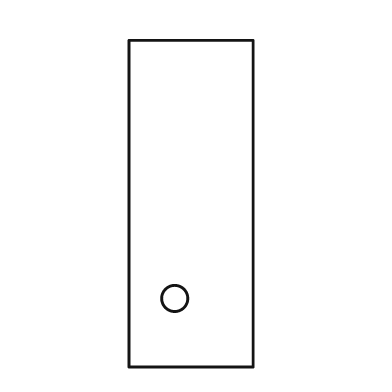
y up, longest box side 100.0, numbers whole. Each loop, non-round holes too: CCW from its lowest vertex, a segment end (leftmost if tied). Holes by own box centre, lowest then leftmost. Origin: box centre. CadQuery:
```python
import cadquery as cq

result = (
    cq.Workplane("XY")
    .moveTo(-19.0, -50.0)
    .lineTo(19.0, -50.0)
    .lineTo(19.0, 50.0)
    .lineTo(-19.0, 50.0)
    .close()
    .moveTo(-5.0, -29.0)
    .circle(4.0)
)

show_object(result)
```